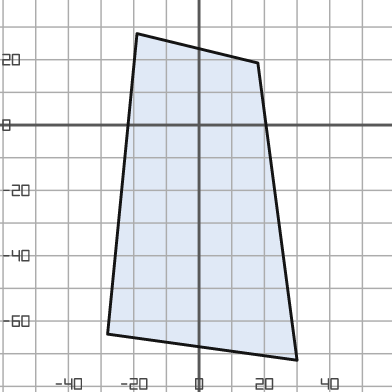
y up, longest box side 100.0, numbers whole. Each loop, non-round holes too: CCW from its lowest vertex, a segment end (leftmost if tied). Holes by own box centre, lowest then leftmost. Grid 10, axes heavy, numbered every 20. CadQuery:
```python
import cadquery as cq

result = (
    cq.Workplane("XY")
    .moveTo(30.0, -72.0)
    .lineTo(18.0, 19.0)
    .lineTo(-19.0, 28.0)
    .lineTo(-28.0, -64.0)
    .close()
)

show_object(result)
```